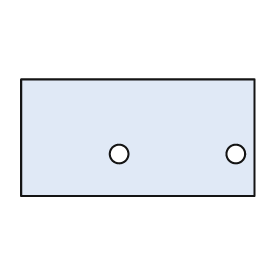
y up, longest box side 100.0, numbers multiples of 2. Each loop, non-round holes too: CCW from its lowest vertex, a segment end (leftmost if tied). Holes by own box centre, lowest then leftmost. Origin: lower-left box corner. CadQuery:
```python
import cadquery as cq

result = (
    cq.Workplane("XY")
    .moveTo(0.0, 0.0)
    .lineTo(100.0, 0.0)
    .lineTo(100.0, 50.0)
    .lineTo(0.0, 50.0)
    .close()
    .moveTo(42.0, 18.0)
    .circle(4.0)
    .moveTo(92.0, 18.0)
    .circle(4.0)
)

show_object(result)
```